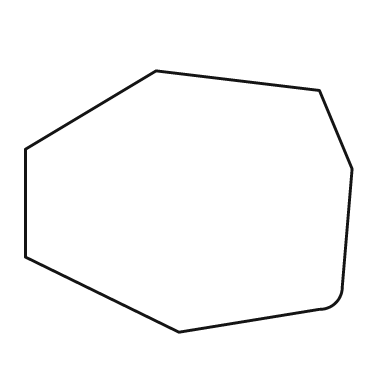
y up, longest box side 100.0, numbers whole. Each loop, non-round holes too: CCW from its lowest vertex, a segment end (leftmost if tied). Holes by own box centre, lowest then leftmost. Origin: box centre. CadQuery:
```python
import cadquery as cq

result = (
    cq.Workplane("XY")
    .moveTo(-3.0, -40.0)
    .lineTo(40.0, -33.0)
    .threePointArc((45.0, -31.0), (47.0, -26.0))
    .lineTo(50.0, 10.0)
    .lineTo(40.0, 34.0)
    .lineTo(-10.0, 40.0)
    .lineTo(-50.0, 16.0)
    .lineTo(-50.0, -17.0)
    .close()
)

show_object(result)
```